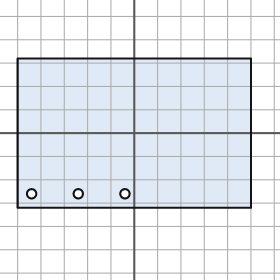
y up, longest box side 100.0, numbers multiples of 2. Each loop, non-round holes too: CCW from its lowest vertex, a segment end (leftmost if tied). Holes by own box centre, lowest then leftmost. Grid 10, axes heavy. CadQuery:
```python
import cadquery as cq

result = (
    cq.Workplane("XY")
    .moveTo(-50.0, -32.0)
    .lineTo(50.0, -32.0)
    .lineTo(50.0, 32.0)
    .lineTo(-50.0, 32.0)
    .close()
    .moveTo(-44.0, -26.0)
    .circle(2.0)
    .moveTo(-24.0, -26.0)
    .circle(2.0)
    .moveTo(-4.0, -26.0)
    .circle(2.0)
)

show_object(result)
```